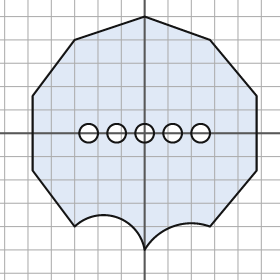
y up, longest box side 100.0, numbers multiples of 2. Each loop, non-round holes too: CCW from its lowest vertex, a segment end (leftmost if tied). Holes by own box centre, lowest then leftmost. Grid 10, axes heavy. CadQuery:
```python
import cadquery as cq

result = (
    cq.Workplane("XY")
    .moveTo(0.0, -50.0)
    .threePointArc((12.0, -40.0), (28.0, -40.0))
    .lineTo(48.0, -16.0)
    .lineTo(48.0, 16.0)
    .lineTo(28.0, 40.0)
    .lineTo(0.0, 50.0)
    .lineTo(-30.0, 40.0)
    .lineTo(-48.0, 16.0)
    .lineTo(-48.0, -16.0)
    .lineTo(-30.0, -40.0)
    .threePointArc((-12.0, -36.0), (0.0, -50.0))
    .close()
    .moveTo(-24.0, 0.0)
    .circle(4.0)
    .moveTo(-12.0, 0.0)
    .circle(4.0)
    .moveTo(0.0, 0.0)
    .circle(4.0)
    .moveTo(12.0, 0.0)
    .circle(4.0)
    .moveTo(24.0, 0.0)
    .circle(4.0)
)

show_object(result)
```